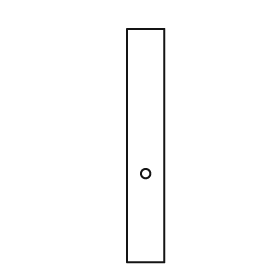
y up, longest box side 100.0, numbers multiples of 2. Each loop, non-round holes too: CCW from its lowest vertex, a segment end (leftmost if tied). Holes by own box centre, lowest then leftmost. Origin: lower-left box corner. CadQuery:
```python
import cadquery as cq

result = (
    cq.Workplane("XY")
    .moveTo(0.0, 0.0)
    .lineTo(16.0, 0.0)
    .lineTo(16.0, 100.0)
    .lineTo(0.0, 100.0)
    .close()
    .moveTo(8.0, 38.0)
    .circle(2.0)
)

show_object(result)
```